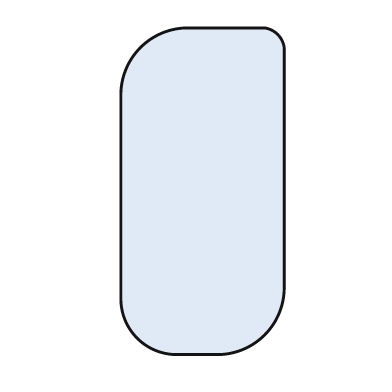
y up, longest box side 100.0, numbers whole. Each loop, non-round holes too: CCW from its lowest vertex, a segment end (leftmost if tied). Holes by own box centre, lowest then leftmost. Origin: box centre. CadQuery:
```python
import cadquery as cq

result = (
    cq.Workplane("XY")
    .moveTo(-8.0, -50.0)
    .lineTo(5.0, -50.0)
    .threePointArc((19.0, -44.0), (25.0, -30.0))
    .lineTo(25.0, 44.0)
    .threePointArc((23.0, 48.0), (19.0, 50.0))
    .lineTo(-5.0, 50.0)
    .threePointArc((-19.0, 44.0), (-25.0, 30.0))
    .lineTo(-25.0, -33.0)
    .threePointArc((-20.0, -45.0), (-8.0, -50.0))
    .close()
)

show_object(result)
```